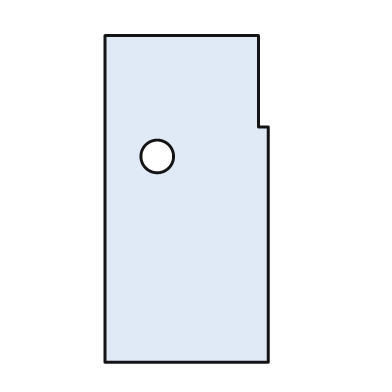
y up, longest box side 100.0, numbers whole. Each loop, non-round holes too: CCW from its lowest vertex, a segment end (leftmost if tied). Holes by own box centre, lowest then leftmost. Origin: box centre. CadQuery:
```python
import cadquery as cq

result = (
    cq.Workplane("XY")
    .moveTo(-25.0, -50.0)
    .lineTo(25.0, -50.0)
    .lineTo(25.0, 22.0)
    .lineTo(22.0, 22.0)
    .lineTo(22.0, 50.0)
    .lineTo(-25.0, 50.0)
    .close()
    .moveTo(-9.0, 13.0)
    .circle(5.0)
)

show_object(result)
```